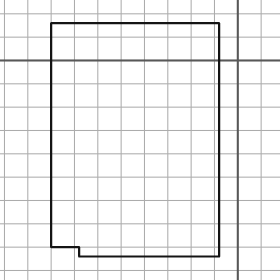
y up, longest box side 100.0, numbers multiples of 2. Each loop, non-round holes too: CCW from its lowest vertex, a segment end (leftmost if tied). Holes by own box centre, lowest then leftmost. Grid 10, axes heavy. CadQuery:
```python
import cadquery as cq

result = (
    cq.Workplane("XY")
    .moveTo(-68.0, -84.0)
    .lineTo(-8.0, -84.0)
    .lineTo(-8.0, 16.0)
    .lineTo(-80.0, 16.0)
    .lineTo(-80.0, -80.0)
    .lineTo(-68.0, -80.0)
    .close()
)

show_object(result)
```